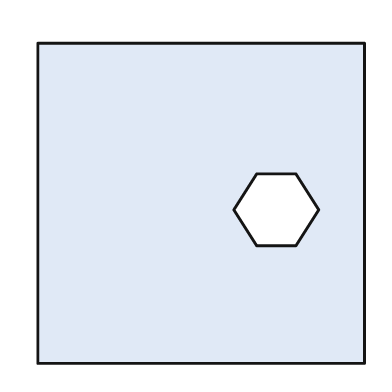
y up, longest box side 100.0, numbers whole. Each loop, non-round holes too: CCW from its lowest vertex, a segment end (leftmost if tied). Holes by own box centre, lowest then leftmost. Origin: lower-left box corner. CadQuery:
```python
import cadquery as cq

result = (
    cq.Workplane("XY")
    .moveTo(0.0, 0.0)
    .lineTo(100.0, 0.0)
    .lineTo(100.0, 98.0)
    .lineTo(0.0, 98.0)
    .close()
    .moveTo(67.0, 36.0)
    .lineTo(79.0, 36.0)
    .lineTo(86.0, 47.0)
    .lineTo(79.0, 58.0)
    .lineTo(67.0, 58.0)
    .lineTo(60.0, 47.0)
    .close()
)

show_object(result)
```